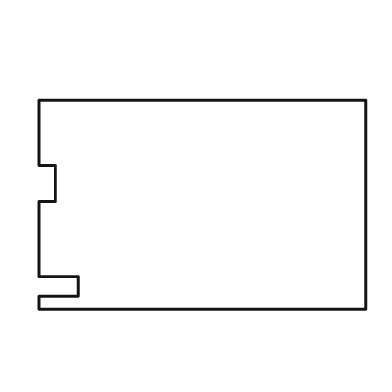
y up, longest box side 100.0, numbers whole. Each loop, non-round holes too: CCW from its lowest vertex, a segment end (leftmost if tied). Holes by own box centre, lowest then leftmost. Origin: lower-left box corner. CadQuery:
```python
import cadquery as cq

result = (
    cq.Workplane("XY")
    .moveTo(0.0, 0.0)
    .lineTo(100.0, 0.0)
    .lineTo(100.0, 64.0)
    .lineTo(0.0, 64.0)
    .lineTo(0.0, 44.0)
    .lineTo(5.0, 44.0)
    .lineTo(5.0, 33.0)
    .lineTo(0.0, 33.0)
    .lineTo(0.0, 10.0)
    .lineTo(12.0, 10.0)
    .lineTo(12.0, 4.0)
    .lineTo(0.0, 4.0)
    .close()
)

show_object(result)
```